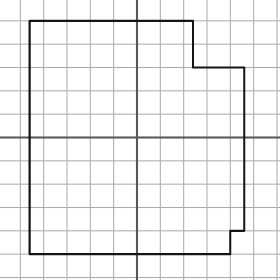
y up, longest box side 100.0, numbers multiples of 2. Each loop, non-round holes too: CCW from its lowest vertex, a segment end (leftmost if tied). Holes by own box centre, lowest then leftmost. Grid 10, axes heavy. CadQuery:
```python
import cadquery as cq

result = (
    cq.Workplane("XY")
    .moveTo(-46.0, -50.0)
    .lineTo(40.0, -50.0)
    .lineTo(40.0, -40.0)
    .lineTo(46.0, -40.0)
    .lineTo(46.0, 30.0)
    .lineTo(24.0, 30.0)
    .lineTo(24.0, 50.0)
    .lineTo(-46.0, 50.0)
    .close()
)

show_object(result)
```